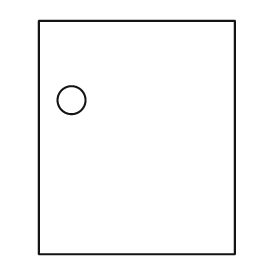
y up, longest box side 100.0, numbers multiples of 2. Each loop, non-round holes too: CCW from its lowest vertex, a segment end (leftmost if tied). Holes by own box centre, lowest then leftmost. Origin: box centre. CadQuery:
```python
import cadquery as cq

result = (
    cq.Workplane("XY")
    .moveTo(-42.0, -50.0)
    .lineTo(42.0, -50.0)
    .lineTo(42.0, 50.0)
    .lineTo(-42.0, 50.0)
    .close()
    .moveTo(-28.0, 16.0)
    .circle(6.0)
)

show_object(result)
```